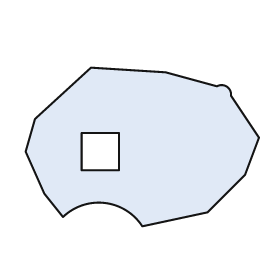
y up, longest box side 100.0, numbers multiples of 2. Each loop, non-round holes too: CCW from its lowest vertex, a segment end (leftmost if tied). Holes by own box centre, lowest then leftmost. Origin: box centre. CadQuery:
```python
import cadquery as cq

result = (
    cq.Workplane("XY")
    .moveTo(0.0, -34.0)
    .lineTo(28.0, -28.0)
    .lineTo(44.0, -12.0)
    .lineTo(50.0, 4.0)
    .lineTo(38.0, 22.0)
    .threePointArc((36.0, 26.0), (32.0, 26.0))
    .lineTo(10.0, 32.0)
    .lineTo(-22.0, 34.0)
    .lineTo(-46.0, 12.0)
    .lineTo(-50.0, -2.0)
    .lineTo(-42.0, -20.0)
    .lineTo(-34.0, -30.0)
    .threePointArc((-16.0, -24.0), (0.0, -34.0))
    .close()
    .moveTo(-26.0, -10.0)
    .lineTo(-10.0, -10.0)
    .lineTo(-10.0, 6.0)
    .lineTo(-26.0, 6.0)
    .close()
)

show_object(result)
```